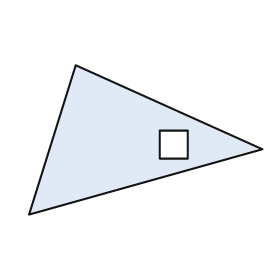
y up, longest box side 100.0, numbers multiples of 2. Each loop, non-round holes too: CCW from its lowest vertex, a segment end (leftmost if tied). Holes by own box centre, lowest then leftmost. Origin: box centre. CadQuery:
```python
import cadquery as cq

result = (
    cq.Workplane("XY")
    .moveTo(-50.0, -32.0)
    .lineTo(50.0, -4.0)
    .lineTo(-30.0, 32.0)
    .close()
    .moveTo(6.0, -8.0)
    .lineTo(18.0, -8.0)
    .lineTo(18.0, 4.0)
    .lineTo(6.0, 4.0)
    .close()
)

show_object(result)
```